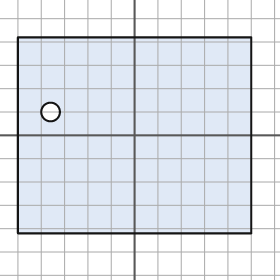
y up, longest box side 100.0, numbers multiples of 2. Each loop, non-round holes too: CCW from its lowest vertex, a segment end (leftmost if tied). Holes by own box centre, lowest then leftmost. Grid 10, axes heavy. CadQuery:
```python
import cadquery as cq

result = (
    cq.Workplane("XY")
    .moveTo(-50.0, -42.0)
    .lineTo(50.0, -42.0)
    .lineTo(50.0, 42.0)
    .lineTo(-50.0, 42.0)
    .close()
    .moveTo(-36.0, 10.0)
    .circle(4.0)
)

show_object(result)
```